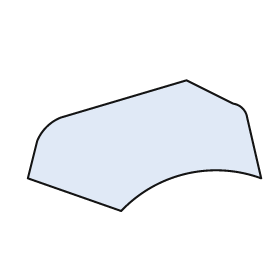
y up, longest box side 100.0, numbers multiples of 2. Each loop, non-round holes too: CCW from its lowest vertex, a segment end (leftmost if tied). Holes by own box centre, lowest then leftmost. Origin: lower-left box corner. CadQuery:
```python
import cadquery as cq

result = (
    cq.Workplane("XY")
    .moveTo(40.0, 0.0)
    .threePointArc((68.0, 16.0), (100.0, 14.0))
    .lineTo(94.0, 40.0)
    .threePointArc((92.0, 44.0), (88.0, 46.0))
    .lineTo(68.0, 56.0)
    .lineTo(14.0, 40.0)
    .threePointArc((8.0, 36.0), (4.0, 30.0))
    .lineTo(0.0, 14.0)
    .close()
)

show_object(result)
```